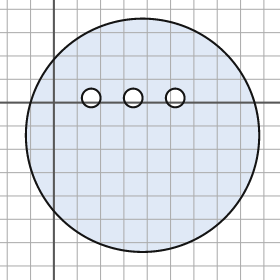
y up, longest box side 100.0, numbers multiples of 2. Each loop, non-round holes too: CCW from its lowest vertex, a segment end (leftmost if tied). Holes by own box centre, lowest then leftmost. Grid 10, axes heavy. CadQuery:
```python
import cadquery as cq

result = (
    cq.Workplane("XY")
    .moveTo(38.0, -14.0)
    .circle(50.0)
    .moveTo(16.0, 2.0)
    .circle(4.0)
    .moveTo(34.0, 2.0)
    .circle(4.0)
    .moveTo(52.0, 2.0)
    .circle(4.0)
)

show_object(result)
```